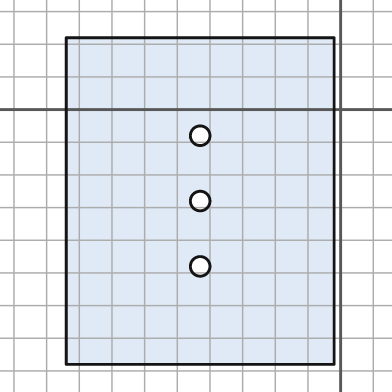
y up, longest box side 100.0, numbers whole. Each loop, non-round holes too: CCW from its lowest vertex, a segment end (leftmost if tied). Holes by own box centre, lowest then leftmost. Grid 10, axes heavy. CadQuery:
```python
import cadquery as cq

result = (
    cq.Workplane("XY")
    .moveTo(-84.0, -78.0)
    .lineTo(-2.0, -78.0)
    .lineTo(-2.0, 22.0)
    .lineTo(-84.0, 22.0)
    .close()
    .moveTo(-43.0, -48.0)
    .circle(3.0)
    .moveTo(-43.0, -28.0)
    .circle(3.0)
    .moveTo(-43.0, -8.0)
    .circle(3.0)
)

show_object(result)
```